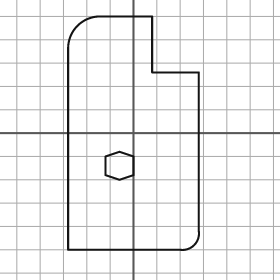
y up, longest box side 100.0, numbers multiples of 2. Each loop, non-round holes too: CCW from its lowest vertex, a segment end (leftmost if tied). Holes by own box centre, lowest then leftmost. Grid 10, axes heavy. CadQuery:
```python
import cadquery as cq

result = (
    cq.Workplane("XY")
    .moveTo(-28.0, -50.0)
    .lineTo(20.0, -50.0)
    .threePointArc((26.0, -48.0), (28.0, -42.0))
    .lineTo(28.0, 26.0)
    .lineTo(8.0, 26.0)
    .lineTo(8.0, 50.0)
    .lineTo(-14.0, 50.0)
    .threePointArc((-24.0, 46.0), (-28.0, 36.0))
    .close()
    .moveTo(-6.0, -20.0)
    .lineTo(0.0, -18.0)
    .lineTo(0.0, -10.0)
    .lineTo(-6.0, -8.0)
    .lineTo(-12.0, -10.0)
    .lineTo(-12.0, -18.0)
    .close()
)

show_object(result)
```